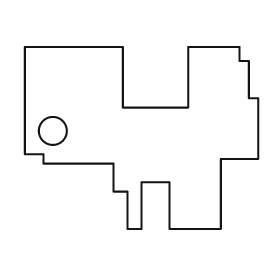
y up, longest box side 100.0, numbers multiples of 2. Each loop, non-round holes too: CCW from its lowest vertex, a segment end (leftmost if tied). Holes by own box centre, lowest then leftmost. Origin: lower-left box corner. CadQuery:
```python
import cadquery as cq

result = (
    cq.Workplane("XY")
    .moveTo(44.0, 0.0)
    .lineTo(50.0, 0.0)
    .lineTo(50.0, 20.0)
    .lineTo(62.0, 20.0)
    .lineTo(62.0, 0.0)
    .lineTo(84.0, 0.0)
    .lineTo(84.0, 30.0)
    .lineTo(100.0, 30.0)
    .lineTo(100.0, 56.0)
    .lineTo(96.0, 56.0)
    .lineTo(96.0, 72.0)
    .lineTo(92.0, 72.0)
    .lineTo(92.0, 78.0)
    .lineTo(70.0, 78.0)
    .lineTo(70.0, 52.0)
    .lineTo(42.0, 52.0)
    .lineTo(42.0, 78.0)
    .lineTo(0.0, 78.0)
    .lineTo(0.0, 32.0)
    .lineTo(8.0, 32.0)
    .lineTo(8.0, 28.0)
    .lineTo(38.0, 28.0)
    .lineTo(38.0, 16.0)
    .lineTo(44.0, 16.0)
    .close()
    .moveTo(12.0, 42.0)
    .circle(6.0)
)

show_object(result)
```